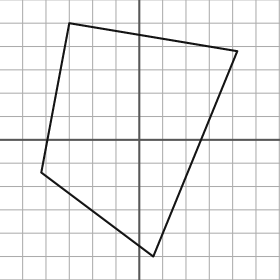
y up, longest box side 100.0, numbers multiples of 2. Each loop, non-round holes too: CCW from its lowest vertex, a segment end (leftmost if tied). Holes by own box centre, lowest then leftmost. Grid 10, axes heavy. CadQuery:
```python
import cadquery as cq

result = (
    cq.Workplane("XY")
    .moveTo(6.0, -50.0)
    .lineTo(42.0, 38.0)
    .lineTo(-30.0, 50.0)
    .lineTo(-42.0, -14.0)
    .close()
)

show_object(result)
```